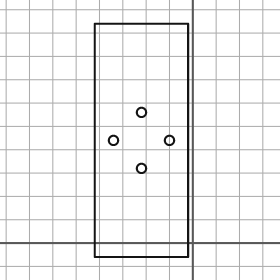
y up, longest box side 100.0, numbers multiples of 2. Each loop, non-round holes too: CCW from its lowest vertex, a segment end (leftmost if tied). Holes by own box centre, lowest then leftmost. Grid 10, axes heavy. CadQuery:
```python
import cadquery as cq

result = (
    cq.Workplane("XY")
    .moveTo(-42.0, -6.0)
    .lineTo(-2.0, -6.0)
    .lineTo(-2.0, 94.0)
    .lineTo(-42.0, 94.0)
    .close()
    .moveTo(-22.0, 32.0)
    .circle(2.0)
    .moveTo(-34.0, 44.0)
    .circle(2.0)
    .moveTo(-10.0, 44.0)
    .circle(2.0)
    .moveTo(-22.0, 56.0)
    .circle(2.0)
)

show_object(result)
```